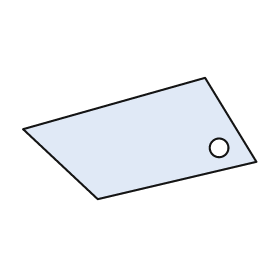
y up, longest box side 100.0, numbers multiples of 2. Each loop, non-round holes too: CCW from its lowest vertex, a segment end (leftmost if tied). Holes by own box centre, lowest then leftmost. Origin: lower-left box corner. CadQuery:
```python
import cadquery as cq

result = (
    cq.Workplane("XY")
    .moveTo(32.0, 0.0)
    .lineTo(100.0, 16.0)
    .lineTo(78.0, 52.0)
    .lineTo(0.0, 30.0)
    .close()
    .moveTo(84.0, 22.0)
    .circle(4.0)
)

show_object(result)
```